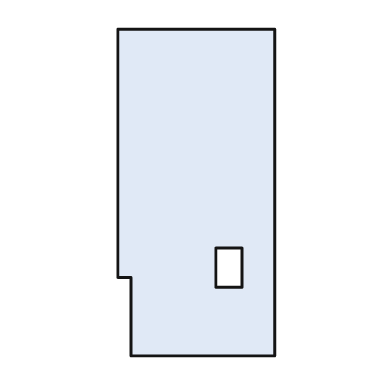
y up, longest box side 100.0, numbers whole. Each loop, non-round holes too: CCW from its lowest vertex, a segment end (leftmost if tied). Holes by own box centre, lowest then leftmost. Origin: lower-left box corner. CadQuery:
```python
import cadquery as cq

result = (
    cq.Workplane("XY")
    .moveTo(4.0, 0.0)
    .lineTo(48.0, 0.0)
    .lineTo(48.0, 100.0)
    .lineTo(0.0, 100.0)
    .lineTo(0.0, 24.0)
    .lineTo(4.0, 24.0)
    .close()
    .moveTo(30.0, 21.0)
    .lineTo(38.0, 21.0)
    .lineTo(38.0, 33.0)
    .lineTo(30.0, 33.0)
    .close()
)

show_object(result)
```